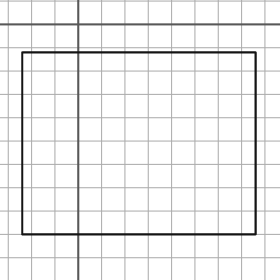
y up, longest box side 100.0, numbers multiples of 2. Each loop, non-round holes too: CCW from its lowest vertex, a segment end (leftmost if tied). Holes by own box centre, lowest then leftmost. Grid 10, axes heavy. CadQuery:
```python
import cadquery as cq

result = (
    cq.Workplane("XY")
    .moveTo(-24.0, -90.0)
    .lineTo(76.0, -90.0)
    .lineTo(76.0, -12.0)
    .lineTo(-24.0, -12.0)
    .close()
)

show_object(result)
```